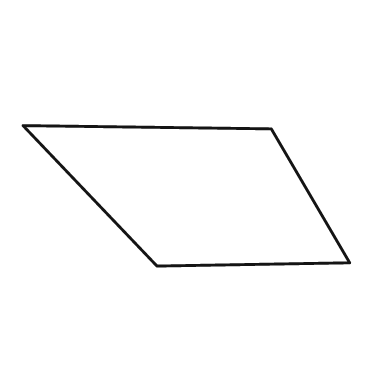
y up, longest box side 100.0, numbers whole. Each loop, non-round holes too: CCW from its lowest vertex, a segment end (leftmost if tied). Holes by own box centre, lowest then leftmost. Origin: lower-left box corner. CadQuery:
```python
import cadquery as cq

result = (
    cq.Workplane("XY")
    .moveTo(41.0, 0.0)
    .lineTo(100.0, 1.0)
    .lineTo(76.0, 42.0)
    .lineTo(0.0, 43.0)
    .close()
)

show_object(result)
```